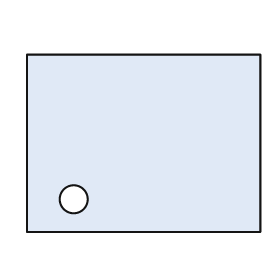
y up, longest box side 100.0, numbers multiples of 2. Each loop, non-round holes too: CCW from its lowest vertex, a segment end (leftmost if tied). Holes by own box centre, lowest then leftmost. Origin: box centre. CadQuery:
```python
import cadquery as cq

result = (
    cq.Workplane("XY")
    .moveTo(-50.0, -38.0)
    .lineTo(50.0, -38.0)
    .lineTo(50.0, 38.0)
    .lineTo(-50.0, 38.0)
    .close()
    .moveTo(-30.0, -24.0)
    .circle(6.0)
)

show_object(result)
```